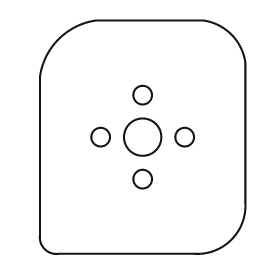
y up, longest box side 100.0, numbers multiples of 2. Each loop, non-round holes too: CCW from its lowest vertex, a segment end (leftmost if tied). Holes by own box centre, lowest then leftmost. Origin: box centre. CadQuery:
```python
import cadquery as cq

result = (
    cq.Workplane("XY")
    .moveTo(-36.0, -50.0)
    .lineTo(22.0, -50.0)
    .threePointArc((38.0, -44.0), (44.0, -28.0))
    .lineTo(44.0, 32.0)
    .threePointArc((38.0, 44.0), (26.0, 50.0))
    .lineTo(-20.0, 50.0)
    .threePointArc((-36.0, 42.0), (-44.0, 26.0))
    .lineTo(-44.0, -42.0)
    .threePointArc((-42.0, -48.0), (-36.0, -50.0))
    .close()
    .moveTo(0.0, -18.0)
    .circle(4.0)
    .moveTo(-18.0, 0.0)
    .circle(4.0)
    .moveTo(0.0, 0.0)
    .circle(8.0)
    .moveTo(18.0, 0.0)
    .circle(4.0)
    .moveTo(0.0, 18.0)
    .circle(4.0)
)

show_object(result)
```